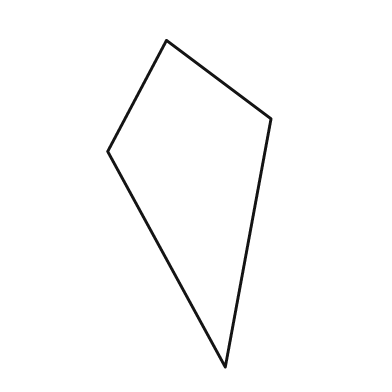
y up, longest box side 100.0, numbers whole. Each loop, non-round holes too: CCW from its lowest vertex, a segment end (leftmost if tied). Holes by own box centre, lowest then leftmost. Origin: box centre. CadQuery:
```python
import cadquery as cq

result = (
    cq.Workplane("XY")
    .moveTo(11.0, -50.0)
    .lineTo(25.0, 26.0)
    .lineTo(-7.0, 50.0)
    .lineTo(-25.0, 16.0)
    .close()
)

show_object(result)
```